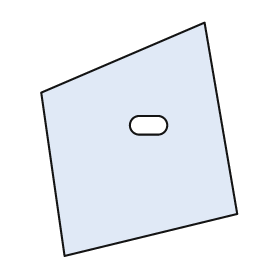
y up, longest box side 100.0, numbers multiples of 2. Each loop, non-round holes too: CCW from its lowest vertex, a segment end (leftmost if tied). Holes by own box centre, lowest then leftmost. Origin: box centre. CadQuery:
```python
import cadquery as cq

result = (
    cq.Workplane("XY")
    .moveTo(-32.0, -50.0)
    .lineTo(42.0, -32.0)
    .lineTo(28.0, 50.0)
    .lineTo(-42.0, 20.0)
    .close()
    .moveTo(0.0, 2.0)
    .lineTo(8.0, 2.0)
    .threePointArc((12.0, 6.0), (8.0, 10.0))
    .lineTo(0.0, 10.0)
    .threePointArc((-4.0, 6.0), (0.0, 2.0))
    .close()
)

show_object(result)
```